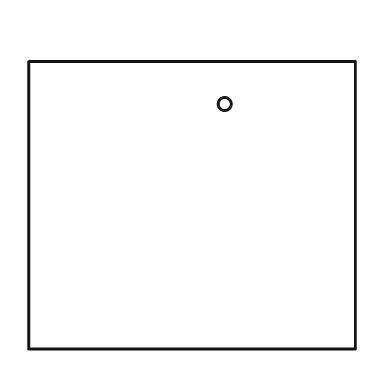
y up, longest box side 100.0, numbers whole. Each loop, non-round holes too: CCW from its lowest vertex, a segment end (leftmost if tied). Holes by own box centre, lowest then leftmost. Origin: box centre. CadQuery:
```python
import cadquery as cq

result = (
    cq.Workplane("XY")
    .moveTo(-50.0, -44.0)
    .lineTo(50.0, -44.0)
    .lineTo(50.0, 44.0)
    .lineTo(-50.0, 44.0)
    .close()
    .moveTo(10.0, 31.0)
    .circle(2.0)
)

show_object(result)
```